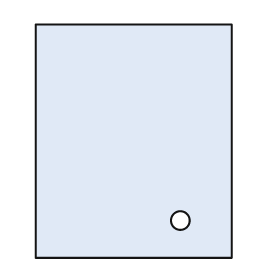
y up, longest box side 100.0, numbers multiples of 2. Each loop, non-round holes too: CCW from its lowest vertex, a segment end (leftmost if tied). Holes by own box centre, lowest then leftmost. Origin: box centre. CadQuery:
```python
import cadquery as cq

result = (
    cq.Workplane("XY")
    .moveTo(-42.0, -50.0)
    .lineTo(42.0, -50.0)
    .lineTo(42.0, 50.0)
    .lineTo(-42.0, 50.0)
    .close()
    .moveTo(20.0, -34.0)
    .circle(4.0)
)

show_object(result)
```